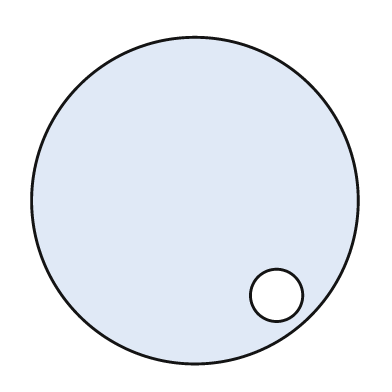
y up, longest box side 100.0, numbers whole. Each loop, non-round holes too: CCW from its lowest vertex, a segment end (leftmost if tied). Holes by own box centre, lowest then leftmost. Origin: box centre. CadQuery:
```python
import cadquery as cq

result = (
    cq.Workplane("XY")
    .moveTo(0.0, 0.0)
    .circle(50.0)
    .moveTo(25.0, -29.0)
    .circle(8.0)
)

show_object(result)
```